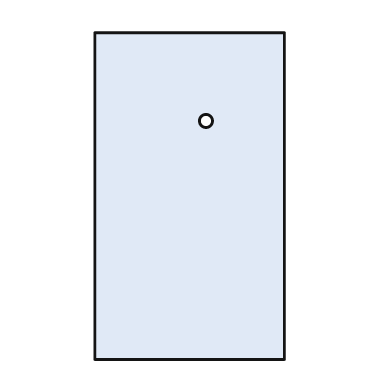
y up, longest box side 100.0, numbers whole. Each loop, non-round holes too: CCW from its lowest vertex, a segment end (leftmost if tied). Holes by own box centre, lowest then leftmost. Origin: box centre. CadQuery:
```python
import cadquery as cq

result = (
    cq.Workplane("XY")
    .moveTo(-29.0, -50.0)
    .lineTo(29.0, -50.0)
    .lineTo(29.0, 50.0)
    .lineTo(-29.0, 50.0)
    .close()
    .moveTo(5.0, 23.0)
    .circle(2.0)
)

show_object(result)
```